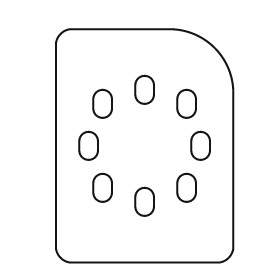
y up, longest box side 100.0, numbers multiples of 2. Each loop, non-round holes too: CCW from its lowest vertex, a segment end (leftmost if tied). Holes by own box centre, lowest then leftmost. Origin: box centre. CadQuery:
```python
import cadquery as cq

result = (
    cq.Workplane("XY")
    .moveTo(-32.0, -50.0)
    .lineTo(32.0, -50.0)
    .threePointArc((36.0, -48.0), (38.0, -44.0))
    .lineTo(38.0, 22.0)
    .threePointArc((30.0, 42.0), (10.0, 50.0))
    .lineTo(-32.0, 50.0)
    .threePointArc((-36.0, 48.0), (-38.0, 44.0))
    .lineTo(-38.0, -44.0)
    .threePointArc((-36.0, -48.0), (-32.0, -50.0))
    .close()
    .moveTo(-4.0, -26.0)
    .threePointArc((0.0, -30.0), (4.0, -26.0))
    .lineTo(4.0, -22.0)
    .threePointArc((0.0, -18.0), (-4.0, -22.0))
    .close()
    .moveTo(-22.0, -20.0)
    .threePointArc((-18.0, -24.0), (-14.0, -20.0))
    .lineTo(-14.0, -16.0)
    .threePointArc((-18.0, -12.0), (-22.0, -16.0))
    .close()
    .moveTo(14.0, -20.0)
    .threePointArc((18.0, -24.0), (22.0, -20.0))
    .lineTo(22.0, -16.0)
    .threePointArc((18.0, -12.0), (14.0, -16.0))
    .close()
    .moveTo(-28.0, -2.0)
    .threePointArc((-24.0, -6.0), (-20.0, -2.0))
    .lineTo(-20.0, 2.0)
    .threePointArc((-24.0, 6.0), (-28.0, 2.0))
    .close()
    .moveTo(20.0, -2.0)
    .threePointArc((24.0, -6.0), (28.0, -2.0))
    .lineTo(28.0, 2.0)
    .threePointArc((24.0, 6.0), (20.0, 2.0))
    .close()
    .moveTo(-22.0, 16.0)
    .threePointArc((-18.0, 12.0), (-14.0, 16.0))
    .lineTo(-14.0, 20.0)
    .threePointArc((-18.0, 24.0), (-22.0, 20.0))
    .close()
    .moveTo(14.0, 16.0)
    .threePointArc((18.0, 12.0), (22.0, 16.0))
    .lineTo(22.0, 20.0)
    .threePointArc((18.0, 24.0), (14.0, 20.0))
    .close()
    .moveTo(-4.0, 22.0)
    .threePointArc((0.0, 18.0), (4.0, 22.0))
    .lineTo(4.0, 26.0)
    .threePointArc((0.0, 30.0), (-4.0, 26.0))
    .close()
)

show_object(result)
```